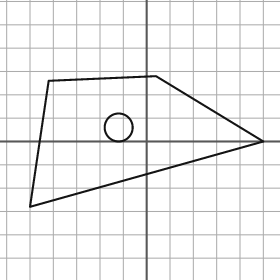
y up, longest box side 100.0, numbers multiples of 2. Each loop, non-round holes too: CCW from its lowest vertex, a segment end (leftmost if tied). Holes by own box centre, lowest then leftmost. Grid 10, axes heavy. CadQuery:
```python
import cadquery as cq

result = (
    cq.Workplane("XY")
    .moveTo(-50.0, -28.0)
    .lineTo(50.0, 0.0)
    .lineTo(4.0, 28.0)
    .lineTo(-42.0, 26.0)
    .close()
    .moveTo(-12.0, 6.0)
    .circle(6.0)
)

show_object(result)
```